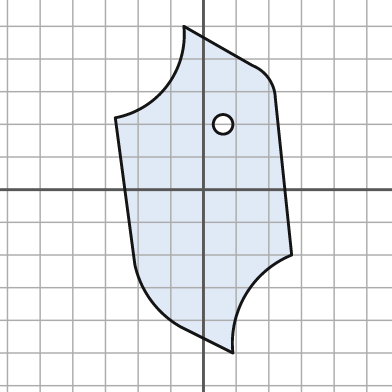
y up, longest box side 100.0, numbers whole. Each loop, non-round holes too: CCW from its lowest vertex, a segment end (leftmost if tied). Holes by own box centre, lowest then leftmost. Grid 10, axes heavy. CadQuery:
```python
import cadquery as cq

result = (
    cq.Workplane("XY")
    .moveTo(9.0, -50.0)
    .threePointArc((13.0, -32.0), (27.0, -20.0))
    .lineTo(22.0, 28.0)
    .threePointArc((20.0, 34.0), (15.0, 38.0))
    .lineTo(-6.0, 50.0)
    .threePointArc((-11.0, 32.0), (-27.0, 22.0))
    .lineTo(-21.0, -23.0)
    .threePointArc((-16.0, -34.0), (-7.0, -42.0))
    .close()
    .moveTo(6.0, 20.0)
    .circle(3.0)
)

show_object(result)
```